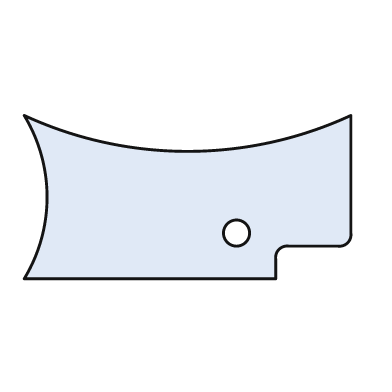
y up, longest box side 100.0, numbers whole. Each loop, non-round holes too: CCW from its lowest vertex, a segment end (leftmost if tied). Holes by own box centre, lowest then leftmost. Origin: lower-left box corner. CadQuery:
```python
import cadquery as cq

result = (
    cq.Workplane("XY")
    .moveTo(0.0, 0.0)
    .lineTo(77.0, 0.0)
    .lineTo(77.0, 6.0)
    .threePointArc((78.0, 9.0), (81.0, 10.0))
    .lineTo(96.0, 10.0)
    .threePointArc((99.0, 11.0), (100.0, 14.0))
    .lineTo(100.0, 50.0)
    .threePointArc((50.0, 39.0), (0.0, 50.0))
    .threePointArc((7.0, 25.0), (0.0, 0.0))
    .close()
    .moveTo(65.0, 14.0)
    .circle(4.0)
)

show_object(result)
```